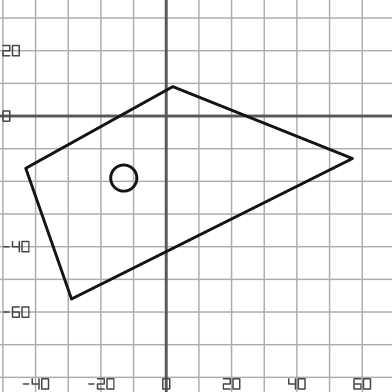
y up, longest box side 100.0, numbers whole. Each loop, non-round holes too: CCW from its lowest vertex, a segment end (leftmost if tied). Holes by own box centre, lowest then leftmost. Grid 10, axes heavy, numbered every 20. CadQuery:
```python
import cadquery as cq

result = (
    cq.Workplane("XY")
    .moveTo(-29.0, -56.0)
    .lineTo(57.0, -13.0)
    .lineTo(2.0, 9.0)
    .lineTo(-43.0, -16.0)
    .close()
    .moveTo(-13.0, -19.0)
    .circle(4.0)
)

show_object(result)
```